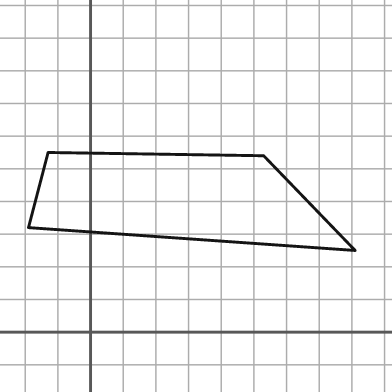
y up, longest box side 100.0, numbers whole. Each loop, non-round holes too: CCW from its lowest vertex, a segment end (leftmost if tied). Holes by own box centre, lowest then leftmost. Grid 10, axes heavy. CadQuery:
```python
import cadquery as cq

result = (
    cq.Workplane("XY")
    .moveTo(81.0, 25.0)
    .lineTo(53.0, 54.0)
    .lineTo(-13.0, 55.0)
    .lineTo(-19.0, 32.0)
    .close()
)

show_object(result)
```